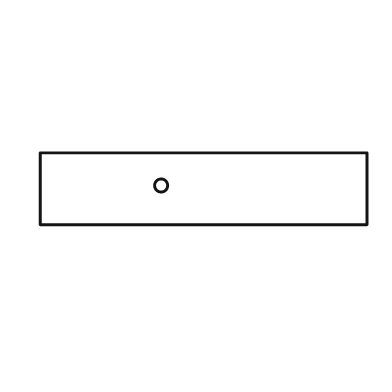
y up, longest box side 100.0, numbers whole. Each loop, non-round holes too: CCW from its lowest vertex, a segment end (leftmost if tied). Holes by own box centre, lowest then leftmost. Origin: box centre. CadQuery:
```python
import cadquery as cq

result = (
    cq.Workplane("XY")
    .moveTo(-50.0, -11.0)
    .lineTo(50.0, -11.0)
    .lineTo(50.0, 11.0)
    .lineTo(-50.0, 11.0)
    .close()
    .moveTo(-13.0, 1.0)
    .circle(2.0)
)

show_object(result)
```